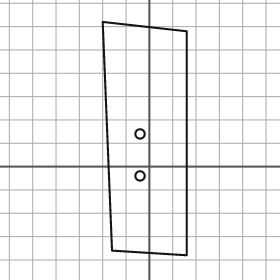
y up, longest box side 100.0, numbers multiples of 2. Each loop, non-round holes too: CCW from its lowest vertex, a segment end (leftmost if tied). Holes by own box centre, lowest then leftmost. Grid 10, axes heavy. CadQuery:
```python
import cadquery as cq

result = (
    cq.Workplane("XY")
    .moveTo(16.0, -38.0)
    .lineTo(16.0, 58.0)
    .lineTo(-20.0, 62.0)
    .lineTo(-16.0, -36.0)
    .close()
    .moveTo(-4.0, -4.0)
    .circle(2.0)
    .moveTo(-4.0, 14.0)
    .circle(2.0)
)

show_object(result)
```